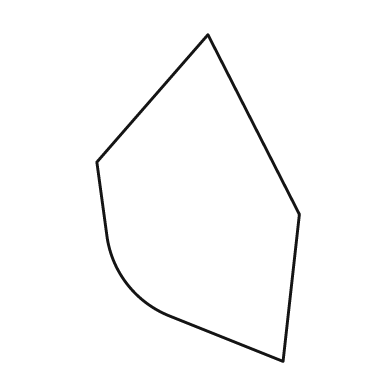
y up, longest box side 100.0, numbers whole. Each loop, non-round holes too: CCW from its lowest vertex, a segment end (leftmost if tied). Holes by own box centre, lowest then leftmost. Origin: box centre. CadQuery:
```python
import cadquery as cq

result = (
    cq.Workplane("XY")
    .moveTo(26.0, -50.0)
    .lineTo(31.0, -5.0)
    .lineTo(3.0, 50.0)
    .lineTo(-31.0, 11.0)
    .lineTo(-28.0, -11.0)
    .threePointArc((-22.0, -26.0), (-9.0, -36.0))
    .close()
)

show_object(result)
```